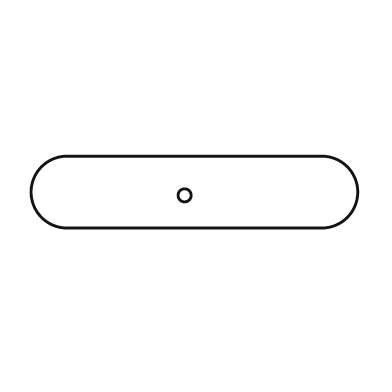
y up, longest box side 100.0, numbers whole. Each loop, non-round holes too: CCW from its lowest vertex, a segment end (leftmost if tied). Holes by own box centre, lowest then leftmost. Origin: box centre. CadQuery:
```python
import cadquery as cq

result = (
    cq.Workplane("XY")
    .moveTo(-39.0, -11.0)
    .lineTo(39.0, -11.0)
    .threePointArc((50.0, 0.0), (39.0, 11.0))
    .lineTo(-39.0, 11.0)
    .threePointArc((-50.0, 0.0), (-39.0, -11.0))
    .close()
    .moveTo(-3.0, -1.0)
    .circle(2.0)
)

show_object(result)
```